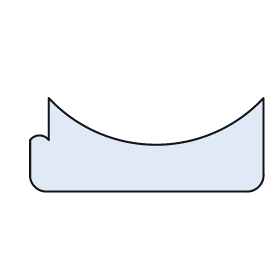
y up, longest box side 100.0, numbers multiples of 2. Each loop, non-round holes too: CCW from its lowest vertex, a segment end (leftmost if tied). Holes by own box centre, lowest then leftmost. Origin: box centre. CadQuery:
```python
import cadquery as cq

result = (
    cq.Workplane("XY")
    .moveTo(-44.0, -20.0)
    .lineTo(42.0, -20.0)
    .threePointArc((48.0, -18.0), (50.0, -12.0))
    .lineTo(50.0, 20.0)
    .threePointArc((4.0, 0.0), (-42.0, 20.0))
    .lineTo(-42.0, 2.0)
    .threePointArc((-46.0, 4.0), (-50.0, 2.0))
    .lineTo(-50.0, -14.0)
    .threePointArc((-48.0, -18.0), (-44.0, -20.0))
    .close()
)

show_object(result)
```